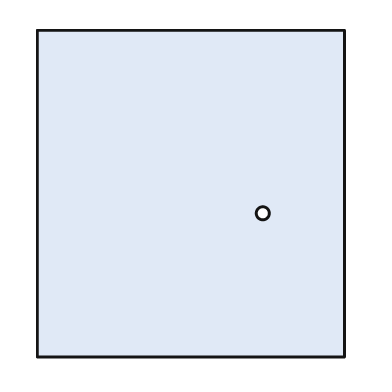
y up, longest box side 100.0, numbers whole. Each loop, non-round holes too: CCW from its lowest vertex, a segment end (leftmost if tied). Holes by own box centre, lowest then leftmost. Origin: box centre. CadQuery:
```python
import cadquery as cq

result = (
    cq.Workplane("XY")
    .moveTo(-47.0, -50.0)
    .lineTo(47.0, -50.0)
    .lineTo(47.0, 50.0)
    .lineTo(-47.0, 50.0)
    .close()
    .moveTo(22.0, -6.0)
    .circle(2.0)
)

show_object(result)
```